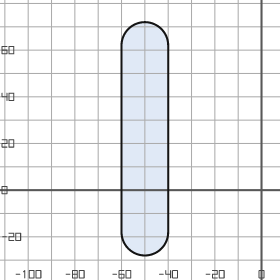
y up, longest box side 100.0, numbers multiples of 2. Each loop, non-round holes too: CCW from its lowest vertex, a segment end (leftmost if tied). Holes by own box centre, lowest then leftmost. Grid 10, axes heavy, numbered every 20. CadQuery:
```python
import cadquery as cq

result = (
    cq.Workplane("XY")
    .moveTo(-60.0, -18.0)
    .threePointArc((-50.0, -28.0), (-40.0, -18.0))
    .lineTo(-40.0, 62.0)
    .threePointArc((-50.0, 72.0), (-60.0, 62.0))
    .close()
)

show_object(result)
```